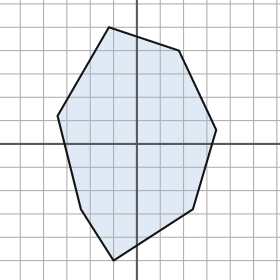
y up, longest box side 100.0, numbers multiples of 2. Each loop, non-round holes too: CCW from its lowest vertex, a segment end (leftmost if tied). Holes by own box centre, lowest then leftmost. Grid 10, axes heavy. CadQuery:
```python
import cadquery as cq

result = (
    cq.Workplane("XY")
    .moveTo(-10.0, -50.0)
    .lineTo(24.0, -28.0)
    .lineTo(34.0, 6.0)
    .lineTo(18.0, 40.0)
    .lineTo(-12.0, 50.0)
    .lineTo(-34.0, 12.0)
    .lineTo(-24.0, -28.0)
    .close()
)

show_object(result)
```